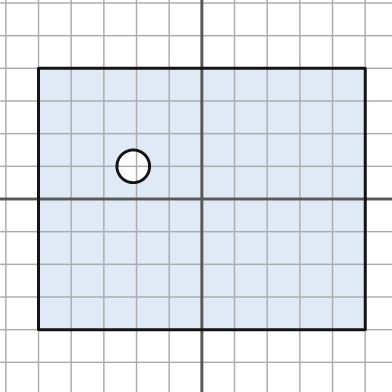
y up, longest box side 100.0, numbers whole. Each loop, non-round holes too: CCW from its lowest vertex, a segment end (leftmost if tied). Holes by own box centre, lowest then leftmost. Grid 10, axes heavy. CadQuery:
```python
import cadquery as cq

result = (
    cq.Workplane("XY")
    .moveTo(-50.0, -40.0)
    .lineTo(50.0, -40.0)
    .lineTo(50.0, 40.0)
    .lineTo(-50.0, 40.0)
    .close()
    .moveTo(-21.0, 10.0)
    .circle(5.0)
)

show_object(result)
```